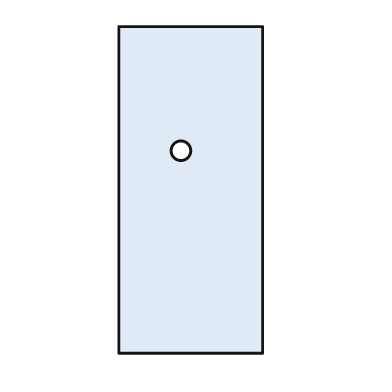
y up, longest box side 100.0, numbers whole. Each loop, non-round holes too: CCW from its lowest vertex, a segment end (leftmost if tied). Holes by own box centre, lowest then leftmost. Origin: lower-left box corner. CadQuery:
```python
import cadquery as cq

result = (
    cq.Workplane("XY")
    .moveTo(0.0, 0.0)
    .lineTo(44.0, 0.0)
    .lineTo(44.0, 100.0)
    .lineTo(0.0, 100.0)
    .close()
    .moveTo(19.0, 62.0)
    .circle(3.0)
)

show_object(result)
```